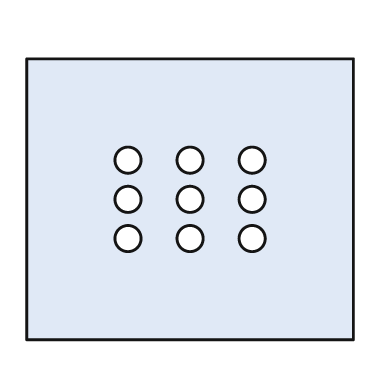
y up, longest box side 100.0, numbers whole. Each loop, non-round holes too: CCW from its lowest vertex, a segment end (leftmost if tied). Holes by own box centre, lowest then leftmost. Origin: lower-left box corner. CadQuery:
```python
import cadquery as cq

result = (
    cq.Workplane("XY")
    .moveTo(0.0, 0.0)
    .lineTo(100.0, 0.0)
    .lineTo(100.0, 86.0)
    .lineTo(0.0, 86.0)
    .close()
    .moveTo(31.0, 31.0)
    .circle(4.0)
    .moveTo(50.0, 31.0)
    .circle(4.0)
    .moveTo(69.0, 31.0)
    .circle(4.0)
    .moveTo(31.0, 43.0)
    .circle(4.0)
    .moveTo(50.0, 43.0)
    .circle(4.0)
    .moveTo(69.0, 43.0)
    .circle(4.0)
    .moveTo(31.0, 55.0)
    .circle(4.0)
    .moveTo(50.0, 55.0)
    .circle(4.0)
    .moveTo(69.0, 55.0)
    .circle(4.0)
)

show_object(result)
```